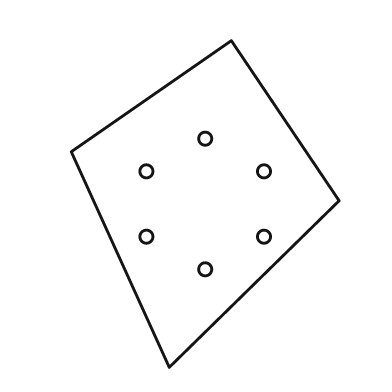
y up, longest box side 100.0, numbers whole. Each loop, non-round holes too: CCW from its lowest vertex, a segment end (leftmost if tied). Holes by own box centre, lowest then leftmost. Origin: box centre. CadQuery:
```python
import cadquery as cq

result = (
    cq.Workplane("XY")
    .moveTo(-11.0, -50.0)
    .lineTo(41.0, 1.0)
    .lineTo(8.0, 50.0)
    .lineTo(-41.0, 16.0)
    .close()
    .moveTo(0.0, -20.0)
    .circle(2.0)
    .moveTo(-18.0, -10.0)
    .circle(2.0)
    .moveTo(18.0, -10.0)
    .circle(2.0)
    .moveTo(-18.0, 10.0)
    .circle(2.0)
    .moveTo(18.0, 10.0)
    .circle(2.0)
    .moveTo(0.0, 20.0)
    .circle(2.0)
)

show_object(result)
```